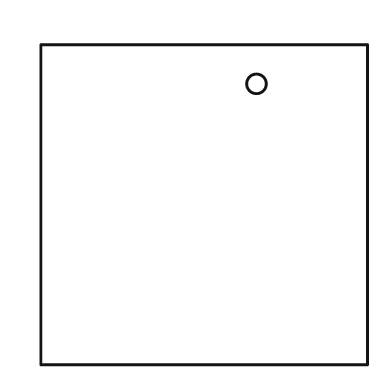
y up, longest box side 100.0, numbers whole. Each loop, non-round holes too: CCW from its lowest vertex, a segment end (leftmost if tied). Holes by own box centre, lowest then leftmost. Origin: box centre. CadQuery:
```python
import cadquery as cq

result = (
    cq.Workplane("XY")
    .moveTo(-50.0, -49.0)
    .lineTo(50.0, -49.0)
    .lineTo(50.0, 49.0)
    .lineTo(-50.0, 49.0)
    .close()
    .moveTo(16.0, 37.0)
    .circle(3.0)
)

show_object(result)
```